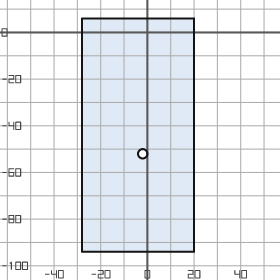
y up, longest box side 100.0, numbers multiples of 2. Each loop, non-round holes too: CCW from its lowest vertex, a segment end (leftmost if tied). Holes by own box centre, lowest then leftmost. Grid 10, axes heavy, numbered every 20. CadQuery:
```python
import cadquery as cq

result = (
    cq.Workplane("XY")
    .moveTo(-28.0, -94.0)
    .lineTo(20.0, -94.0)
    .lineTo(20.0, 6.0)
    .lineTo(-28.0, 6.0)
    .close()
    .moveTo(-2.0, -52.0)
    .circle(2.0)
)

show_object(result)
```